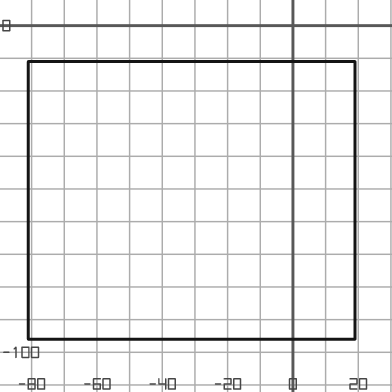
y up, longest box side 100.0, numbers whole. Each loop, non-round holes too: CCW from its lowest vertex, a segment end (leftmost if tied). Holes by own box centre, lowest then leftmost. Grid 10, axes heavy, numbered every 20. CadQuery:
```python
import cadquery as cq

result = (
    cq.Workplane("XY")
    .moveTo(-81.0, -96.0)
    .lineTo(19.0, -96.0)
    .lineTo(19.0, -11.0)
    .lineTo(-81.0, -11.0)
    .close()
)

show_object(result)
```